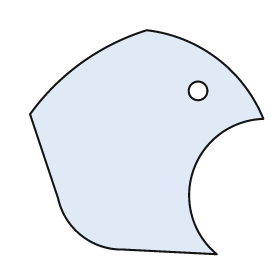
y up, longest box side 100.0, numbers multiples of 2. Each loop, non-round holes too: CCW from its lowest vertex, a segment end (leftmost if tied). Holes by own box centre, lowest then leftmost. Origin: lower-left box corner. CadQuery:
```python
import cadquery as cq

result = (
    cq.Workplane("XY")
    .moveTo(80.0, 0.0)
    .threePointArc((70.0, 36.0), (100.0, 58.0))
    .threePointArc((80.0, 84.0), (50.0, 96.0))
    .threePointArc((22.0, 82.0), (0.0, 60.0))
    .lineTo(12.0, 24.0)
    .threePointArc((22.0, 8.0), (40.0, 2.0))
    .close()
    .moveTo(72.0, 70.0)
    .circle(4.0)
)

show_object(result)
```